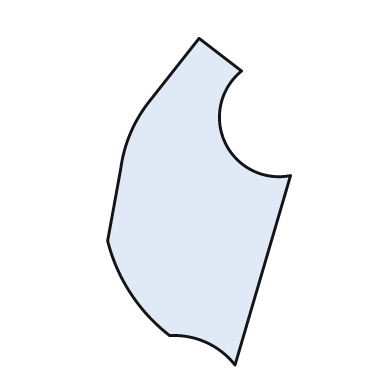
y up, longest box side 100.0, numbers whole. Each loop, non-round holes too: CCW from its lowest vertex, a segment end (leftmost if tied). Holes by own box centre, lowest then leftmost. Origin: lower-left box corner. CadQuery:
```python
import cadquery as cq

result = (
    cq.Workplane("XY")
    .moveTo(39.0, 0.0)
    .lineTo(56.0, 58.0)
    .threePointArc((36.0, 68.0), (41.0, 90.0))
    .lineTo(28.0, 100.0)
    .lineTo(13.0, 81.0)
    .threePointArc((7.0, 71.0), (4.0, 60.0))
    .lineTo(0.0, 38.0)
    .threePointArc((7.0, 22.0), (19.0, 9.0))
    .threePointArc((30.0, 7.0), (39.0, 0.0))
    .close()
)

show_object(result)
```